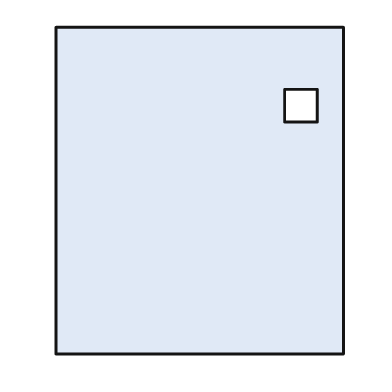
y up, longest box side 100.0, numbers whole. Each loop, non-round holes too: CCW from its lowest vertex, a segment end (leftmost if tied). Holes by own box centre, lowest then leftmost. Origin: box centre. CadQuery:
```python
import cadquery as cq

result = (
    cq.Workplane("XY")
    .moveTo(-44.0, -50.0)
    .lineTo(44.0, -50.0)
    .lineTo(44.0, 50.0)
    .lineTo(-44.0, 50.0)
    .close()
    .moveTo(26.0, 21.0)
    .lineTo(36.0, 21.0)
    .lineTo(36.0, 31.0)
    .lineTo(26.0, 31.0)
    .close()
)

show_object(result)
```